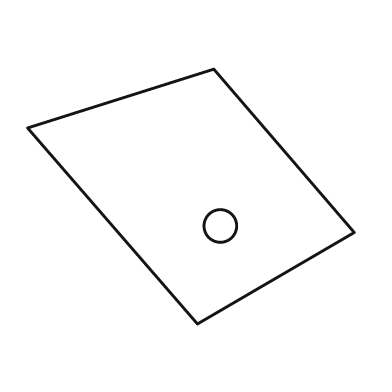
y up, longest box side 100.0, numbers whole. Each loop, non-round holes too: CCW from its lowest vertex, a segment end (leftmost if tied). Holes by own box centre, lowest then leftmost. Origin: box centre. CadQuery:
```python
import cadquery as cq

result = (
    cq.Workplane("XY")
    .moveTo(2.0, -39.0)
    .lineTo(50.0, -11.0)
    .lineTo(7.0, 39.0)
    .lineTo(-50.0, 21.0)
    .close()
    .moveTo(9.0, -9.0)
    .circle(5.0)
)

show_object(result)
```